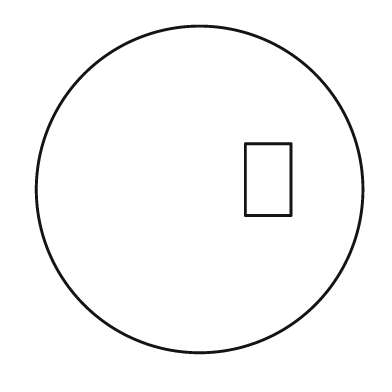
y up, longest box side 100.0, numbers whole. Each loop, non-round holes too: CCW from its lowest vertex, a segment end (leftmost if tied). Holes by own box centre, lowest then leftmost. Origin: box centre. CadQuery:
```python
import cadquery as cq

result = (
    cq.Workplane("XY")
    .moveTo(0.0, 0.0)
    .circle(50.0)
    .moveTo(14.0, -8.0)
    .lineTo(28.0, -8.0)
    .lineTo(28.0, 14.0)
    .lineTo(14.0, 14.0)
    .close()
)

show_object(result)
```